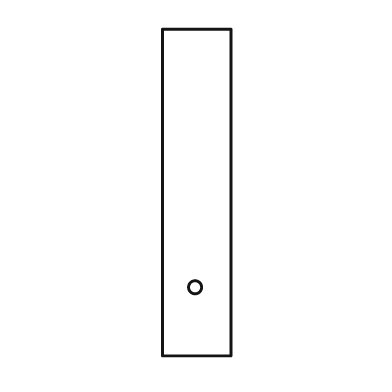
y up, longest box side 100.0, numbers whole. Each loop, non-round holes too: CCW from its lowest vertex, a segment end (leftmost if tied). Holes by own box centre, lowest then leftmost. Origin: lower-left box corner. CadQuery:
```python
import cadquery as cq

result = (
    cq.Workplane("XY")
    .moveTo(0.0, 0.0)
    .lineTo(21.0, 0.0)
    .lineTo(21.0, 100.0)
    .lineTo(0.0, 100.0)
    .close()
    .moveTo(10.0, 21.0)
    .circle(2.0)
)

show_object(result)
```